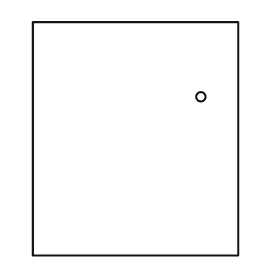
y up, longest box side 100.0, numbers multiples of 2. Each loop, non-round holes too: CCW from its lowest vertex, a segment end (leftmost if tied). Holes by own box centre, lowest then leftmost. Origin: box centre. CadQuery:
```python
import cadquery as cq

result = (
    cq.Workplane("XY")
    .moveTo(-44.0, -50.0)
    .lineTo(44.0, -50.0)
    .lineTo(44.0, 50.0)
    .lineTo(-44.0, 50.0)
    .close()
    .moveTo(28.0, 18.0)
    .circle(2.0)
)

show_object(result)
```